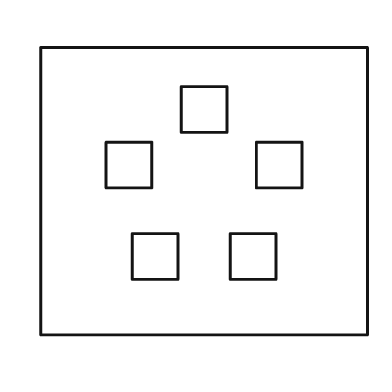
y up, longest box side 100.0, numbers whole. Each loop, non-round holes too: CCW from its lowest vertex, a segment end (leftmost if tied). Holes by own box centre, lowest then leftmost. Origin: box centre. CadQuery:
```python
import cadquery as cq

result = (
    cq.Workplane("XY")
    .moveTo(-50.0, -44.0)
    .lineTo(50.0, -44.0)
    .lineTo(50.0, 44.0)
    .lineTo(-50.0, 44.0)
    .close()
    .moveTo(-22.0, -27.0)
    .lineTo(-8.0, -27.0)
    .lineTo(-8.0, -13.0)
    .lineTo(-22.0, -13.0)
    .close()
    .moveTo(8.0, -27.0)
    .lineTo(22.0, -27.0)
    .lineTo(22.0, -13.0)
    .lineTo(8.0, -13.0)
    .close()
    .moveTo(-30.0, 1.0)
    .lineTo(-16.0, 1.0)
    .lineTo(-16.0, 15.0)
    .lineTo(-30.0, 15.0)
    .close()
    .moveTo(16.0, 1.0)
    .lineTo(30.0, 1.0)
    .lineTo(30.0, 15.0)
    .lineTo(16.0, 15.0)
    .close()
    .moveTo(-7.0, 18.0)
    .lineTo(7.0, 18.0)
    .lineTo(7.0, 32.0)
    .lineTo(-7.0, 32.0)
    .close()
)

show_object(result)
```